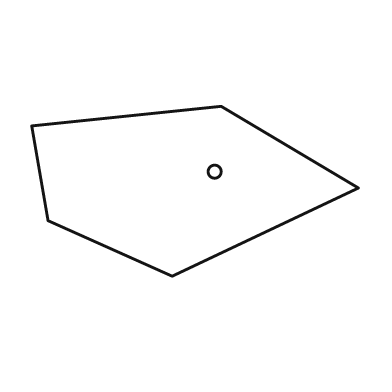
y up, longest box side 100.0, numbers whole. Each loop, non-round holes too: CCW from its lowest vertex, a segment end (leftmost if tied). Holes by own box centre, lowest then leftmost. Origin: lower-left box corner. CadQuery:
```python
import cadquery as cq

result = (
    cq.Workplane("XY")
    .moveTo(43.0, 0.0)
    .lineTo(100.0, 27.0)
    .lineTo(58.0, 52.0)
    .lineTo(0.0, 46.0)
    .lineTo(5.0, 17.0)
    .close()
    .moveTo(56.0, 32.0)
    .circle(2.0)
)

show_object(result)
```